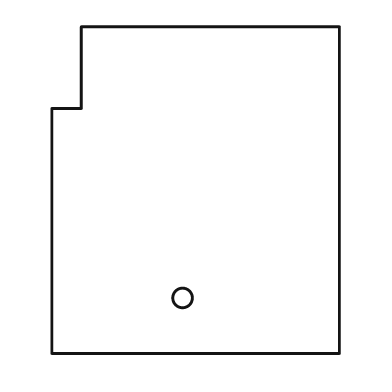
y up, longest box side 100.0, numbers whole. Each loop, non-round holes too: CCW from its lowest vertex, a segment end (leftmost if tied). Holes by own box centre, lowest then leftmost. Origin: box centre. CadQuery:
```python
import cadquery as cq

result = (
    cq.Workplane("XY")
    .moveTo(-44.0, -50.0)
    .lineTo(44.0, -50.0)
    .lineTo(44.0, 50.0)
    .lineTo(-35.0, 50.0)
    .lineTo(-35.0, 25.0)
    .lineTo(-44.0, 25.0)
    .close()
    .moveTo(-4.0, -33.0)
    .circle(3.0)
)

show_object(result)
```